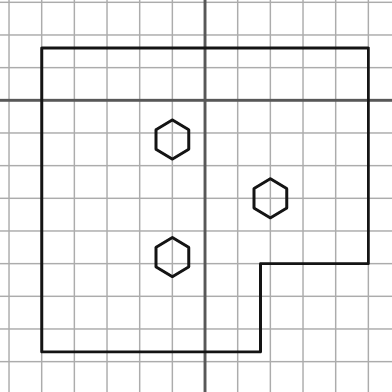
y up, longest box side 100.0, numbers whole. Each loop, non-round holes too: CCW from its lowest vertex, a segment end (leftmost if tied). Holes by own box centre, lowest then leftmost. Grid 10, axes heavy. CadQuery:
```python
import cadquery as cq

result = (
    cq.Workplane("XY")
    .moveTo(-50.0, -77.0)
    .lineTo(17.0, -77.0)
    .lineTo(17.0, -50.0)
    .lineTo(50.0, -50.0)
    .lineTo(50.0, 16.0)
    .lineTo(-50.0, 16.0)
    .close()
    .moveTo(-10.0, -54.0)
    .lineTo(-5.0, -51.0)
    .lineTo(-5.0, -45.0)
    .lineTo(-10.0, -42.0)
    .lineTo(-15.0, -45.0)
    .lineTo(-15.0, -51.0)
    .close()
    .moveTo(20.0, -36.0)
    .lineTo(25.0, -33.0)
    .lineTo(25.0, -27.0)
    .lineTo(20.0, -24.0)
    .lineTo(15.0, -27.0)
    .lineTo(15.0, -33.0)
    .close()
    .moveTo(-10.0, -18.0)
    .lineTo(-5.0, -15.0)
    .lineTo(-5.0, -9.0)
    .lineTo(-10.0, -6.0)
    .lineTo(-15.0, -9.0)
    .lineTo(-15.0, -15.0)
    .close()
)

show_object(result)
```